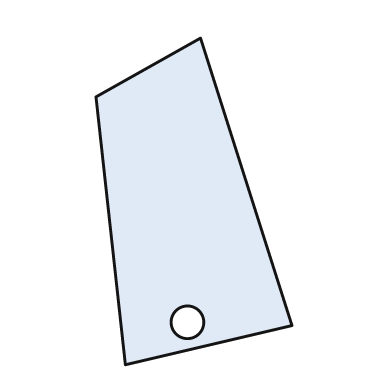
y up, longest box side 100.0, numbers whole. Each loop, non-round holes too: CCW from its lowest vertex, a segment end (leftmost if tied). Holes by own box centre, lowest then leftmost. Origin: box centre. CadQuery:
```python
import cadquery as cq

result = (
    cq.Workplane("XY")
    .moveTo(-21.0, -50.0)
    .lineTo(30.0, -38.0)
    .lineTo(2.0, 50.0)
    .lineTo(-30.0, 32.0)
    .close()
    .moveTo(-2.0, -37.0)
    .circle(5.0)
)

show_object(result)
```